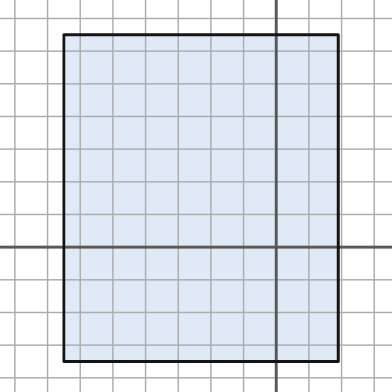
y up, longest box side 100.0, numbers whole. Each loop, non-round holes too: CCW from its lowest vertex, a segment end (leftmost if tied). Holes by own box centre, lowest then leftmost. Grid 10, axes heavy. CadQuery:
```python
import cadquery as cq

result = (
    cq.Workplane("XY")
    .moveTo(-65.0, -35.0)
    .lineTo(19.0, -35.0)
    .lineTo(19.0, 65.0)
    .lineTo(-65.0, 65.0)
    .close()
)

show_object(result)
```